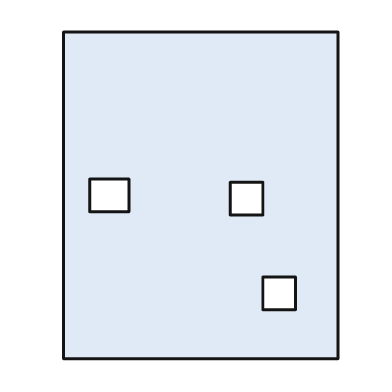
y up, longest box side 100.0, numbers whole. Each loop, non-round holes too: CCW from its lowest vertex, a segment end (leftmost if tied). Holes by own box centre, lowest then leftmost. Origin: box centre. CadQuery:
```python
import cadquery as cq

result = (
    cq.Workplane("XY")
    .moveTo(-42.0, -50.0)
    .lineTo(42.0, -50.0)
    .lineTo(42.0, 50.0)
    .lineTo(-42.0, 50.0)
    .close()
    .moveTo(19.0, -35.0)
    .lineTo(29.0, -35.0)
    .lineTo(29.0, -25.0)
    .lineTo(19.0, -25.0)
    .close()
    .moveTo(9.0, -6.0)
    .lineTo(19.0, -6.0)
    .lineTo(19.0, 4.0)
    .lineTo(9.0, 4.0)
    .close()
    .moveTo(-34.0, -5.0)
    .lineTo(-22.0, -5.0)
    .lineTo(-22.0, 5.0)
    .lineTo(-34.0, 5.0)
    .close()
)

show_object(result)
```